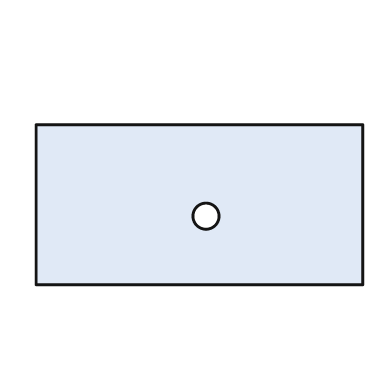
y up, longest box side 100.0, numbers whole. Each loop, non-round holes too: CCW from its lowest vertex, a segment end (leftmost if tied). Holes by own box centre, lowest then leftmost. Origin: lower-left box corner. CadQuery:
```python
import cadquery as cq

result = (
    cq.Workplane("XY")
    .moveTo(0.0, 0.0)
    .lineTo(100.0, 0.0)
    .lineTo(100.0, 49.0)
    .lineTo(0.0, 49.0)
    .close()
    .moveTo(52.0, 21.0)
    .circle(4.0)
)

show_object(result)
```